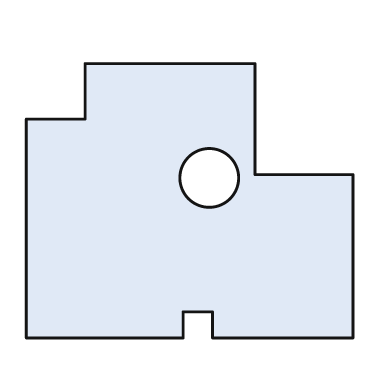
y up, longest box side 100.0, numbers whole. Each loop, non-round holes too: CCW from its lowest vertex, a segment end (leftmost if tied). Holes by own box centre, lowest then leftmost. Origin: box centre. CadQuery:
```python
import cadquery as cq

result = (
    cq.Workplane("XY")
    .moveTo(-50.0, -42.0)
    .lineTo(-2.0, -42.0)
    .lineTo(-2.0, -34.0)
    .lineTo(7.0, -34.0)
    .lineTo(7.0, -42.0)
    .lineTo(50.0, -42.0)
    .lineTo(50.0, 8.0)
    .lineTo(20.0, 8.0)
    .lineTo(20.0, 42.0)
    .lineTo(-32.0, 42.0)
    .lineTo(-32.0, 25.0)
    .lineTo(-50.0, 25.0)
    .close()
    .moveTo(6.0, 7.0)
    .circle(9.0)
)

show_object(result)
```